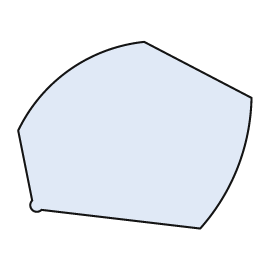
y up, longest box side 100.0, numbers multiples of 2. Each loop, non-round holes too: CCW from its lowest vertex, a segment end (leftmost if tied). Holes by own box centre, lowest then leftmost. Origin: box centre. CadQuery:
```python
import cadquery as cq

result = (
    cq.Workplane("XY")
    .moveTo(28.0, -40.0)
    .threePointArc((44.0, -14.0), (50.0, 16.0))
    .lineTo(4.0, 40.0)
    .threePointArc((-28.0, 28.0), (-50.0, 2.0))
    .lineTo(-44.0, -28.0)
    .threePointArc((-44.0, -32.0), (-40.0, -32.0))
    .close()
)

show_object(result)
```